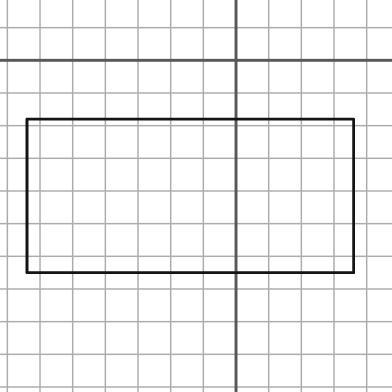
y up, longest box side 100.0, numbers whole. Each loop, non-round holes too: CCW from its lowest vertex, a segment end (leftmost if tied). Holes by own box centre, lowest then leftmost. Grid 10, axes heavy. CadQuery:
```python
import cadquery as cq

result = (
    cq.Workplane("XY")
    .moveTo(-64.0, -65.0)
    .lineTo(36.0, -65.0)
    .lineTo(36.0, -18.0)
    .lineTo(-64.0, -18.0)
    .close()
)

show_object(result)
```